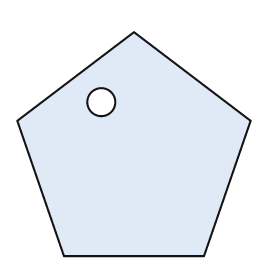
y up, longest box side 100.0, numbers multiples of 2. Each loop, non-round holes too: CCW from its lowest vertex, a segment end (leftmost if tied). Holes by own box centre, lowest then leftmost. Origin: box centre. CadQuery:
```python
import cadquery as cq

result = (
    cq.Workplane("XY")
    .moveTo(-30.0, -48.0)
    .lineTo(30.0, -48.0)
    .lineTo(50.0, 10.0)
    .lineTo(0.0, 48.0)
    .lineTo(-50.0, 10.0)
    .close()
    .moveTo(-14.0, 18.0)
    .circle(6.0)
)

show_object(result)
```